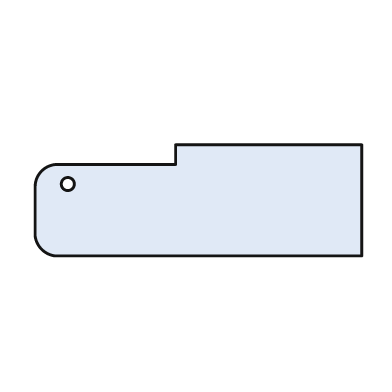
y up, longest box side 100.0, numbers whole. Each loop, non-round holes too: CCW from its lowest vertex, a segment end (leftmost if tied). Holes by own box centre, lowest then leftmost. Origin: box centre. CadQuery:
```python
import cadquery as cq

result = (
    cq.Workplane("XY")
    .moveTo(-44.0, -17.0)
    .lineTo(50.0, -17.0)
    .lineTo(50.0, 17.0)
    .lineTo(-7.0, 17.0)
    .lineTo(-7.0, 11.0)
    .lineTo(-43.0, 11.0)
    .threePointArc((-48.0, 9.0), (-50.0, 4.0))
    .lineTo(-50.0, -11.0)
    .threePointArc((-48.0, -15.0), (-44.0, -17.0))
    .close()
    .moveTo(-40.0, 5.0)
    .circle(2.0)
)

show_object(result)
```